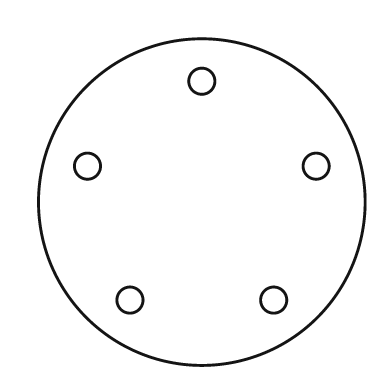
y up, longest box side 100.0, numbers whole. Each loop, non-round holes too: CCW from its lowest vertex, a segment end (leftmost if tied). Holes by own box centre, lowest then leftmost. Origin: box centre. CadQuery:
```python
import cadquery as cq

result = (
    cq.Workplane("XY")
    .moveTo(0.0, 0.0)
    .circle(50.0)
    .moveTo(-22.0, -30.0)
    .circle(4.0)
    .moveTo(22.0, -30.0)
    .circle(4.0)
    .moveTo(-35.0, 11.0)
    .circle(4.0)
    .moveTo(35.0, 11.0)
    .circle(4.0)
    .moveTo(0.0, 37.0)
    .circle(4.0)
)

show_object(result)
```